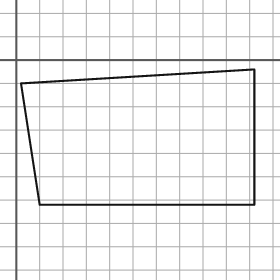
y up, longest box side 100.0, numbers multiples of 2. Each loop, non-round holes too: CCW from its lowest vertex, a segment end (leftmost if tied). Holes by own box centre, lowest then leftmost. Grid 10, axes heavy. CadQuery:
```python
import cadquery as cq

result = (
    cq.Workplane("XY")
    .moveTo(10.0, -62.0)
    .lineTo(102.0, -62.0)
    .lineTo(102.0, -4.0)
    .lineTo(2.0, -10.0)
    .close()
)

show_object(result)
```